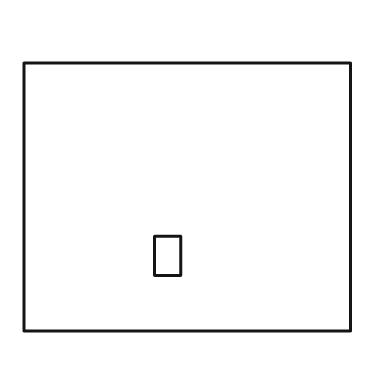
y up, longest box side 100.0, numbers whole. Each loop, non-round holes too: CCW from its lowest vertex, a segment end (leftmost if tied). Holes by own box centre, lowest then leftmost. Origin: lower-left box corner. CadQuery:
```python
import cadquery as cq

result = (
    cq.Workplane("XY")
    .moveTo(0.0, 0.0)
    .lineTo(100.0, 0.0)
    .lineTo(100.0, 82.0)
    .lineTo(0.0, 82.0)
    .close()
    .moveTo(40.0, 17.0)
    .lineTo(48.0, 17.0)
    .lineTo(48.0, 29.0)
    .lineTo(40.0, 29.0)
    .close()
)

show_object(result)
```